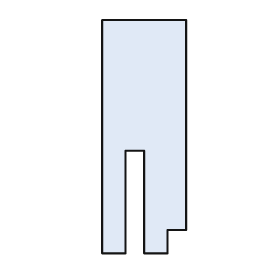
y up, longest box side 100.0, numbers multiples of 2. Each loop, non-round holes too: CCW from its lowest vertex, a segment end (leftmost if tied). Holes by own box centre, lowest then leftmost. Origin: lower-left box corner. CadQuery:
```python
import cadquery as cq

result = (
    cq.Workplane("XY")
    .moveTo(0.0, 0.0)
    .lineTo(10.0, 0.0)
    .lineTo(10.0, 44.0)
    .lineTo(18.0, 44.0)
    .lineTo(18.0, 0.0)
    .lineTo(28.0, 0.0)
    .lineTo(28.0, 10.0)
    .lineTo(36.0, 10.0)
    .lineTo(36.0, 100.0)
    .lineTo(0.0, 100.0)
    .close()
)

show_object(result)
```